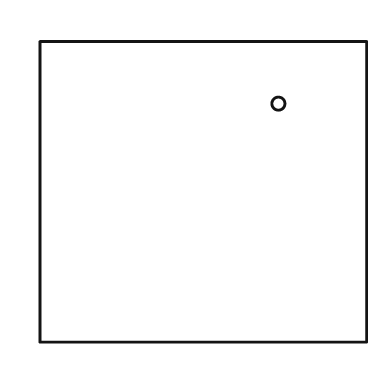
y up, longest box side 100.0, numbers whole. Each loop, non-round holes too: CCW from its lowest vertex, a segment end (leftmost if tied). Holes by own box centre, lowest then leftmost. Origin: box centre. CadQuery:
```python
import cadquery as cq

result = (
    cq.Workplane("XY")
    .moveTo(-50.0, -46.0)
    .lineTo(50.0, -46.0)
    .lineTo(50.0, 46.0)
    .lineTo(-50.0, 46.0)
    .close()
    .moveTo(23.0, 27.0)
    .circle(2.0)
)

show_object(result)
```